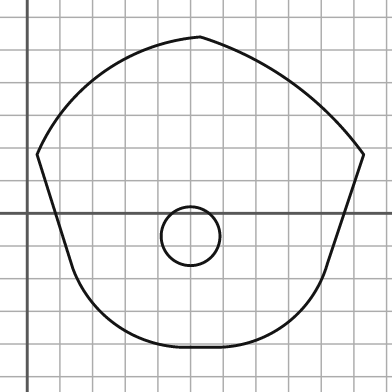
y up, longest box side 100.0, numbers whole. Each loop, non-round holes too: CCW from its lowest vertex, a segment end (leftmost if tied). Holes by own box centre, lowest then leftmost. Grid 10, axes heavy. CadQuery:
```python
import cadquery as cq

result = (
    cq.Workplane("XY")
    .moveTo(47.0, -41.0)
    .lineTo(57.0, -41.0)
    .threePointArc((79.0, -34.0), (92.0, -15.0))
    .lineTo(103.0, 18.0)
    .threePointArc((81.0, 40.0), (53.0, 54.0))
    .threePointArc((23.0, 43.0), (3.0, 18.0))
    .lineTo(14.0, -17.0)
    .threePointArc((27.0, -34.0), (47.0, -41.0))
    .close()
    .moveTo(50.0, -7.0)
    .circle(9.0)
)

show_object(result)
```